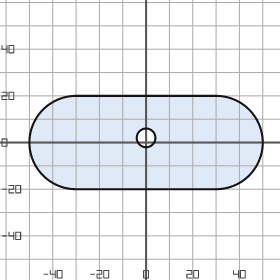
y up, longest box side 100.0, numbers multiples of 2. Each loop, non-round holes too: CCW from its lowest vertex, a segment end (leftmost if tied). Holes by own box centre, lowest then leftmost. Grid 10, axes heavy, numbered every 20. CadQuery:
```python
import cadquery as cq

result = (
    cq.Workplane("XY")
    .moveTo(-30.0, -20.0)
    .lineTo(30.0, -20.0)
    .threePointArc((50.0, 0.0), (30.0, 20.0))
    .lineTo(-30.0, 20.0)
    .threePointArc((-50.0, 0.0), (-30.0, -20.0))
    .close()
    .moveTo(0.0, 2.0)
    .circle(4.0)
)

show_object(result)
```